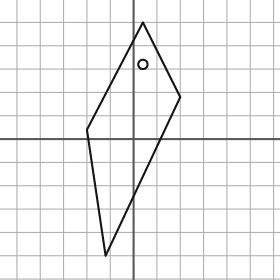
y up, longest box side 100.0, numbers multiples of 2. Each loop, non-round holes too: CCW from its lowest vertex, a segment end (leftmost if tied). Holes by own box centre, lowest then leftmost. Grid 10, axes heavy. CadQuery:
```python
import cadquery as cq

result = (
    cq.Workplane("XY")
    .moveTo(-12.0, -50.0)
    .lineTo(20.0, 18.0)
    .lineTo(4.0, 50.0)
    .lineTo(-20.0, 4.0)
    .close()
    .moveTo(4.0, 32.0)
    .circle(2.0)
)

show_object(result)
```